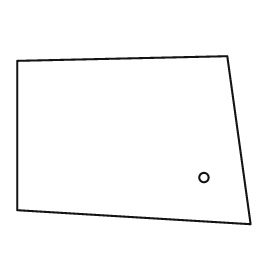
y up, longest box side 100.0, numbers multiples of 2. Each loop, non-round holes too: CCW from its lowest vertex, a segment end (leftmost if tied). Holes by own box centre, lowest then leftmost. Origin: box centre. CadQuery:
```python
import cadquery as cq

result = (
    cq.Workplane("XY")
    .moveTo(50.0, -36.0)
    .lineTo(40.0, 36.0)
    .lineTo(-50.0, 34.0)
    .lineTo(-50.0, -30.0)
    .close()
    .moveTo(30.0, -16.0)
    .circle(2.0)
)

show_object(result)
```